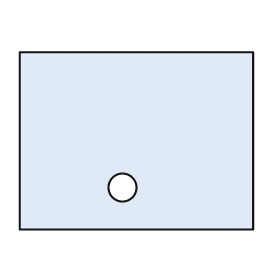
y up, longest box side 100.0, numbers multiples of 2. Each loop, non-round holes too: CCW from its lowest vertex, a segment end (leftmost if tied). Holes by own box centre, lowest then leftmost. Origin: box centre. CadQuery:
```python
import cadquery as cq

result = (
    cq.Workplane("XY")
    .moveTo(-50.0, -38.0)
    .lineTo(50.0, -38.0)
    .lineTo(50.0, 38.0)
    .lineTo(-50.0, 38.0)
    .close()
    .moveTo(-6.0, -20.0)
    .circle(6.0)
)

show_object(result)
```